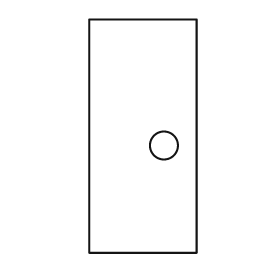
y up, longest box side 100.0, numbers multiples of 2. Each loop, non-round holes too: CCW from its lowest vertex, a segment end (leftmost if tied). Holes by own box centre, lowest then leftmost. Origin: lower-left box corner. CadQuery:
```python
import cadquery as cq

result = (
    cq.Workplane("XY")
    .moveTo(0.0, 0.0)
    .lineTo(46.0, 0.0)
    .lineTo(46.0, 100.0)
    .lineTo(0.0, 100.0)
    .close()
    .moveTo(32.0, 46.0)
    .circle(6.0)
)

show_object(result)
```